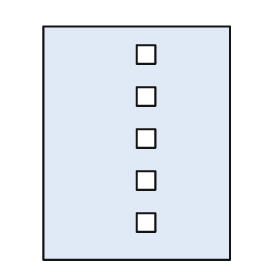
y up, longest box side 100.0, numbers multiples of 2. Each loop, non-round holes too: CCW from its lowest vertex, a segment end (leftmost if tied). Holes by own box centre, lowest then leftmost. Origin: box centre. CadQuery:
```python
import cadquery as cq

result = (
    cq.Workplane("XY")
    .moveTo(-40.0, -50.0)
    .lineTo(40.0, -50.0)
    .lineTo(40.0, 50.0)
    .lineTo(-40.0, 50.0)
    .close()
    .moveTo(0.0, -38.0)
    .lineTo(8.0, -38.0)
    .lineTo(8.0, -30.0)
    .lineTo(0.0, -30.0)
    .close()
    .moveTo(0.0, -20.0)
    .lineTo(8.0, -20.0)
    .lineTo(8.0, -12.0)
    .lineTo(0.0, -12.0)
    .close()
    .moveTo(0.0, -2.0)
    .lineTo(8.0, -2.0)
    .lineTo(8.0, 6.0)
    .lineTo(0.0, 6.0)
    .close()
    .moveTo(0.0, 16.0)
    .lineTo(8.0, 16.0)
    .lineTo(8.0, 24.0)
    .lineTo(0.0, 24.0)
    .close()
    .moveTo(0.0, 34.0)
    .lineTo(8.0, 34.0)
    .lineTo(8.0, 42.0)
    .lineTo(0.0, 42.0)
    .close()
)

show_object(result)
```